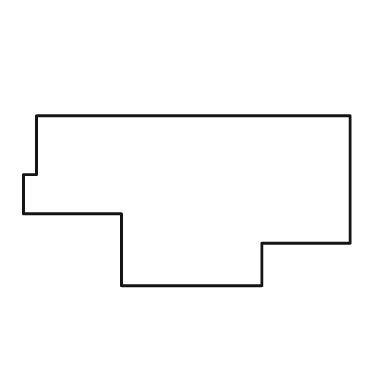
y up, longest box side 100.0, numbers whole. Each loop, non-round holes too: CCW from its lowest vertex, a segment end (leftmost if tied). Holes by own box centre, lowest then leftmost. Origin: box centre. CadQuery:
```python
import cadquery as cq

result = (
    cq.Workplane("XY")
    .moveTo(-20.0, -26.0)
    .lineTo(23.0, -26.0)
    .lineTo(23.0, -13.0)
    .lineTo(50.0, -13.0)
    .lineTo(50.0, 26.0)
    .lineTo(-46.0, 26.0)
    .lineTo(-46.0, 8.0)
    .lineTo(-50.0, 8.0)
    .lineTo(-50.0, -4.0)
    .lineTo(-20.0, -4.0)
    .close()
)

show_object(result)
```